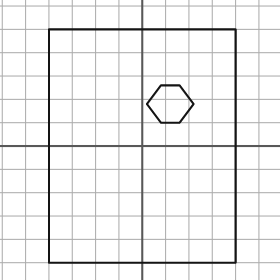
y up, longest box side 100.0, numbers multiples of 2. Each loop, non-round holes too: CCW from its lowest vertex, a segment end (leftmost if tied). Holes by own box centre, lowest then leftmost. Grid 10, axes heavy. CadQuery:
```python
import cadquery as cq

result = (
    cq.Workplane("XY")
    .moveTo(-40.0, -50.0)
    .lineTo(40.0, -50.0)
    .lineTo(40.0, 50.0)
    .lineTo(-40.0, 50.0)
    .close()
    .moveTo(8.0, 10.0)
    .lineTo(16.0, 10.0)
    .lineTo(22.0, 18.0)
    .lineTo(16.0, 26.0)
    .lineTo(8.0, 26.0)
    .lineTo(2.0, 18.0)
    .close()
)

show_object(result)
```